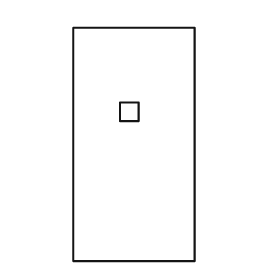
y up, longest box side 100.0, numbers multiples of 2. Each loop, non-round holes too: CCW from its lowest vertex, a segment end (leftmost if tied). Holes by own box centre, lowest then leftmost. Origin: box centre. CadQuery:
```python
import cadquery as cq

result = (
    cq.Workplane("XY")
    .moveTo(-26.0, -50.0)
    .lineTo(26.0, -50.0)
    .lineTo(26.0, 50.0)
    .lineTo(-26.0, 50.0)
    .close()
    .moveTo(-6.0, 10.0)
    .lineTo(2.0, 10.0)
    .lineTo(2.0, 18.0)
    .lineTo(-6.0, 18.0)
    .close()
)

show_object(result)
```